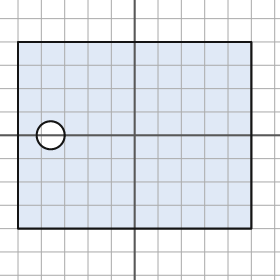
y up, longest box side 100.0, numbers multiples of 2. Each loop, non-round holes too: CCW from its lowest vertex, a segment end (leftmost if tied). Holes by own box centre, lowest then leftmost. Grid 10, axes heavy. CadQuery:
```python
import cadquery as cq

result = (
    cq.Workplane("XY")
    .moveTo(-50.0, -40.0)
    .lineTo(50.0, -40.0)
    .lineTo(50.0, 40.0)
    .lineTo(-50.0, 40.0)
    .close()
    .moveTo(-36.0, 0.0)
    .circle(6.0)
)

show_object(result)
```